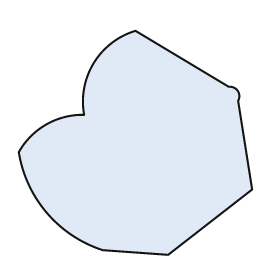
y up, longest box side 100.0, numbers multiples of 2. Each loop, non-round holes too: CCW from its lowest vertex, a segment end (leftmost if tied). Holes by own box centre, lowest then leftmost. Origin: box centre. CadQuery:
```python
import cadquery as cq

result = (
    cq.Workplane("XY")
    .moveTo(14.0, -48.0)
    .lineTo(50.0, -20.0)
    .lineTo(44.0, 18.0)
    .threePointArc((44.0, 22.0), (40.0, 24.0))
    .lineTo(0.0, 48.0)
    .threePointArc((-18.0, 34.0), (-22.0, 12.0))
    .threePointArc((-38.0, 8.0), (-50.0, -4.0))
    .threePointArc((-38.0, -30.0), (-14.0, -46.0))
    .close()
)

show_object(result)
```